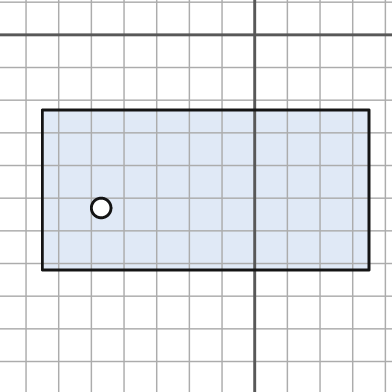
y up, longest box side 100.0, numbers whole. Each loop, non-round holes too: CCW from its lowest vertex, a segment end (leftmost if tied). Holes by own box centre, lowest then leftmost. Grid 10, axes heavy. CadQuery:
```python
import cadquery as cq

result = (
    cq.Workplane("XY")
    .moveTo(-65.0, -72.0)
    .lineTo(35.0, -72.0)
    .lineTo(35.0, -23.0)
    .lineTo(-65.0, -23.0)
    .close()
    .moveTo(-47.0, -53.0)
    .circle(3.0)
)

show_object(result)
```